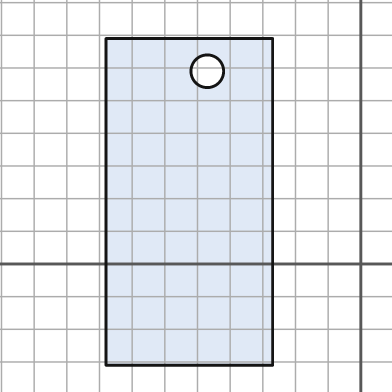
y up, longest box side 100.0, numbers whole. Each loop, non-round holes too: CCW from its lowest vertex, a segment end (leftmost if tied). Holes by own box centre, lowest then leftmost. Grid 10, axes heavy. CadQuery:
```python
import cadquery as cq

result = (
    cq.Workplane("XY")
    .moveTo(-78.0, -31.0)
    .lineTo(-27.0, -31.0)
    .lineTo(-27.0, 69.0)
    .lineTo(-78.0, 69.0)
    .close()
    .moveTo(-47.0, 59.0)
    .circle(5.0)
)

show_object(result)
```